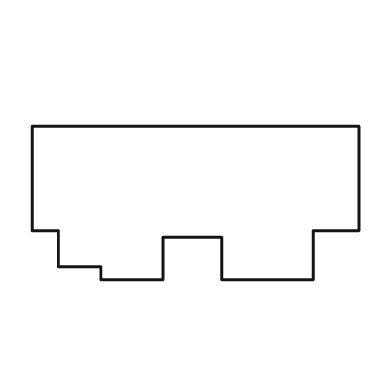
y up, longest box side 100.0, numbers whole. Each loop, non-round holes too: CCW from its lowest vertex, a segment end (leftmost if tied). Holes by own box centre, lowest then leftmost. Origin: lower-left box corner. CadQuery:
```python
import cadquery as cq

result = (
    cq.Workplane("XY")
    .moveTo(21.0, 0.0)
    .lineTo(40.0, 0.0)
    .lineTo(40.0, 13.0)
    .lineTo(58.0, 13.0)
    .lineTo(58.0, 0.0)
    .lineTo(86.0, 0.0)
    .lineTo(86.0, 15.0)
    .lineTo(100.0, 15.0)
    .lineTo(100.0, 47.0)
    .lineTo(0.0, 47.0)
    .lineTo(0.0, 15.0)
    .lineTo(8.0, 15.0)
    .lineTo(8.0, 4.0)
    .lineTo(21.0, 4.0)
    .close()
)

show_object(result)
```